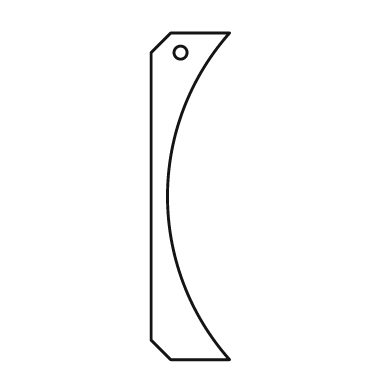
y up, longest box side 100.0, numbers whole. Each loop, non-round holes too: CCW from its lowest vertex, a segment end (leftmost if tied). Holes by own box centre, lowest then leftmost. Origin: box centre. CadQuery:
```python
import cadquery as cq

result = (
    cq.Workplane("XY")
    .moveTo(-6.0, -50.0)
    .lineTo(12.0, -50.0)
    .threePointArc((-7.0, 0.0), (12.0, 50.0))
    .lineTo(-6.0, 50.0)
    .lineTo(-12.0, 44.0)
    .lineTo(-12.0, -44.0)
    .close()
    .moveTo(-3.0, 44.0)
    .circle(2.0)
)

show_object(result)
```